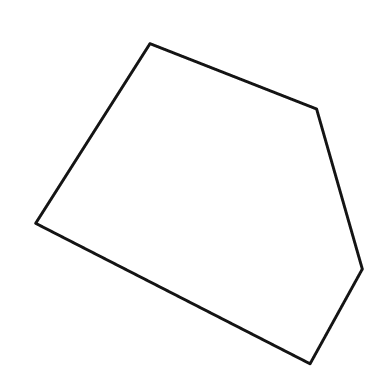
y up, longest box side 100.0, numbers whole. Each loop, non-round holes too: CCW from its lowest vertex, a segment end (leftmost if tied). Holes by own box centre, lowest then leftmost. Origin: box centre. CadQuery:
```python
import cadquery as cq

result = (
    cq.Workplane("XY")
    .moveTo(34.0, -49.0)
    .lineTo(50.0, -20.0)
    .lineTo(36.0, 29.0)
    .lineTo(-15.0, 49.0)
    .lineTo(-50.0, -6.0)
    .close()
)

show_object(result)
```